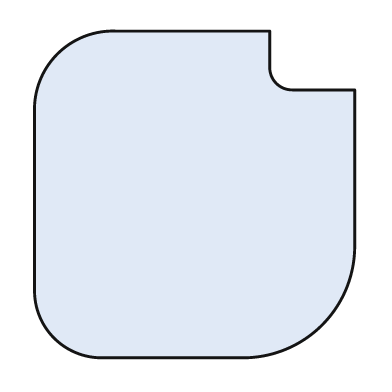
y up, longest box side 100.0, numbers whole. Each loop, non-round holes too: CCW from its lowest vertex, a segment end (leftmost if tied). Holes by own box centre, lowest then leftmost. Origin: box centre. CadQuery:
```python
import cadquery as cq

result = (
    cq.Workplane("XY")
    .moveTo(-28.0, -50.0)
    .lineTo(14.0, -50.0)
    .threePointArc((39.0, -40.0), (49.0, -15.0))
    .lineTo(49.0, 32.0)
    .lineTo(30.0, 32.0)
    .threePointArc((25.0, 34.0), (23.0, 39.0))
    .lineTo(23.0, 50.0)
    .lineTo(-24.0, 50.0)
    .threePointArc((-42.0, 43.0), (-49.0, 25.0))
    .lineTo(-49.0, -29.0)
    .threePointArc((-43.0, -44.0), (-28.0, -50.0))
    .close()
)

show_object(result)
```